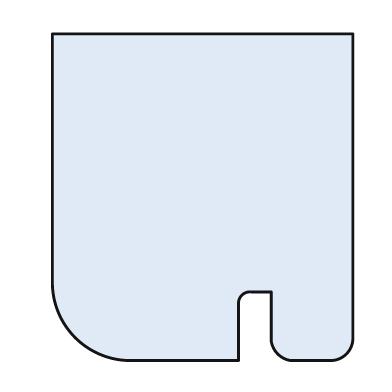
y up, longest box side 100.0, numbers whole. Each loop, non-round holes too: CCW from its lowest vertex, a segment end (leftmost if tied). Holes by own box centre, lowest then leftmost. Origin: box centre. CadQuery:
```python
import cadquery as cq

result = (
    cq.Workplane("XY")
    .moveTo(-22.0, -50.0)
    .lineTo(11.0, -50.0)
    .lineTo(11.0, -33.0)
    .threePointArc((12.0, -30.0), (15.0, -29.0))
    .lineTo(21.0, -29.0)
    .lineTo(21.0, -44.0)
    .threePointArc((23.0, -48.0), (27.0, -50.0))
    .lineTo(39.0, -50.0)
    .threePointArc((44.0, -48.0), (46.0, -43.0))
    .lineTo(46.0, 50.0)
    .lineTo(-46.0, 50.0)
    .lineTo(-46.0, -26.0)
    .threePointArc((-39.0, -43.0), (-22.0, -50.0))
    .close()
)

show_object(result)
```